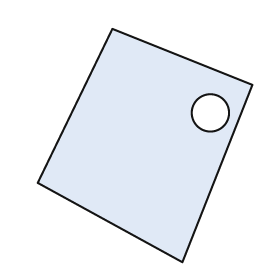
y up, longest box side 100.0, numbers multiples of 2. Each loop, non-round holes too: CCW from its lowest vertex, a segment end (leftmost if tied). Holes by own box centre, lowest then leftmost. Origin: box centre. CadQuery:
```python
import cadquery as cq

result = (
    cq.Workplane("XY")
    .moveTo(16.0, -50.0)
    .lineTo(46.0, 26.0)
    .lineTo(-14.0, 50.0)
    .lineTo(-46.0, -16.0)
    .close()
    .moveTo(28.0, 14.0)
    .circle(8.0)
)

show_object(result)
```